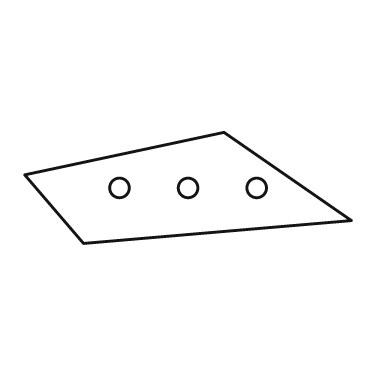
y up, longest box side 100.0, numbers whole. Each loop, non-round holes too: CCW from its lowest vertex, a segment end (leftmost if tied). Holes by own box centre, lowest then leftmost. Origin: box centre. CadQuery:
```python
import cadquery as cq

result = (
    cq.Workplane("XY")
    .moveTo(-32.0, -17.0)
    .lineTo(50.0, -10.0)
    .lineTo(11.0, 17.0)
    .lineTo(-50.0, 4.0)
    .close()
    .moveTo(-21.0, 0.0)
    .circle(3.0)
    .moveTo(0.0, 0.0)
    .circle(3.0)
    .moveTo(21.0, 0.0)
    .circle(3.0)
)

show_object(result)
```